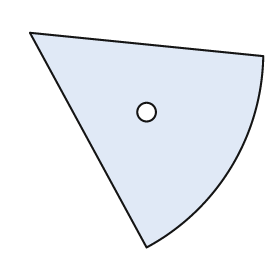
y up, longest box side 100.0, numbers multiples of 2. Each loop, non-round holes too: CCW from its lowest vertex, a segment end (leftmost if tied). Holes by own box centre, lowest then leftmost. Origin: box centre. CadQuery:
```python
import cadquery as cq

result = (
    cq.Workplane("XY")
    .moveTo(0.0, -46.0)
    .threePointArc((36.0, -12.0), (50.0, 36.0))
    .lineTo(-50.0, 46.0)
    .close()
    .moveTo(0.0, 12.0)
    .circle(4.0)
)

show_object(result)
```